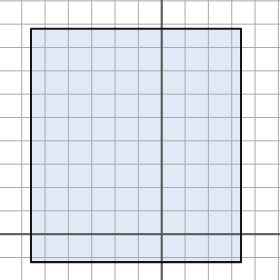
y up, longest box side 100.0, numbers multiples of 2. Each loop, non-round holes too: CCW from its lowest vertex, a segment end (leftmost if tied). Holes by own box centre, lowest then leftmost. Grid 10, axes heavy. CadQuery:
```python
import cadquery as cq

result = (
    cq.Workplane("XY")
    .moveTo(-56.0, -12.0)
    .lineTo(34.0, -12.0)
    .lineTo(34.0, 88.0)
    .lineTo(-56.0, 88.0)
    .close()
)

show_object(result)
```